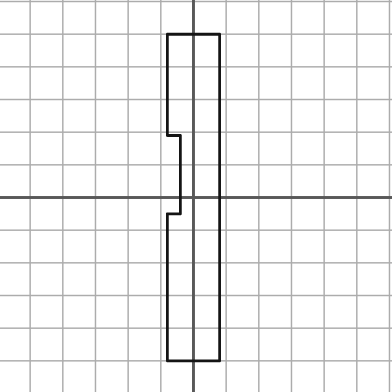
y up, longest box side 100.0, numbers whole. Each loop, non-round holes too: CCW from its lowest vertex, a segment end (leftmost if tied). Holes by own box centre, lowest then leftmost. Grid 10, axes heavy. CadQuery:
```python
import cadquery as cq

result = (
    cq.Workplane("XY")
    .moveTo(-8.0, -50.0)
    .lineTo(8.0, -50.0)
    .lineTo(8.0, 50.0)
    .lineTo(-8.0, 50.0)
    .lineTo(-8.0, 19.0)
    .lineTo(-4.0, 19.0)
    .lineTo(-4.0, -5.0)
    .lineTo(-8.0, -5.0)
    .close()
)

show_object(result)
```